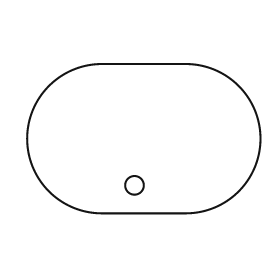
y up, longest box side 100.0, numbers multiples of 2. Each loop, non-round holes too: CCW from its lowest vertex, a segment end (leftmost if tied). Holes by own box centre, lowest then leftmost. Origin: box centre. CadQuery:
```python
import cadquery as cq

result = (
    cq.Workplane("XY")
    .moveTo(-18.0, -32.0)
    .lineTo(18.0, -32.0)
    .threePointArc((50.0, 0.0), (18.0, 32.0))
    .lineTo(-18.0, 32.0)
    .threePointArc((-50.0, 0.0), (-18.0, -32.0))
    .close()
    .moveTo(-4.0, -20.0)
    .circle(4.0)
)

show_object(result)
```